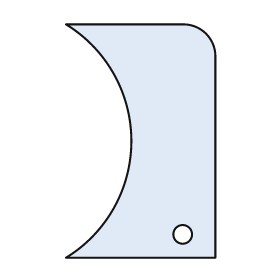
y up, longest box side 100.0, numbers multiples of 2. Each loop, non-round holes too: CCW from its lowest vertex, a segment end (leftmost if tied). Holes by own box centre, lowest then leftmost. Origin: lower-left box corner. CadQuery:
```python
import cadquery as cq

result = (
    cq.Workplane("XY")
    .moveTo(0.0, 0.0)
    .lineTo(64.0, 0.0)
    .lineTo(64.0, 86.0)
    .threePointArc((60.0, 96.0), (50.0, 100.0))
    .lineTo(0.0, 100.0)
    .threePointArc((28.0, 50.0), (0.0, 0.0))
    .close()
    .moveTo(50.0, 10.0)
    .circle(4.0)
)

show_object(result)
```